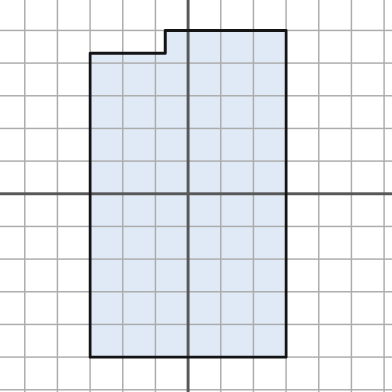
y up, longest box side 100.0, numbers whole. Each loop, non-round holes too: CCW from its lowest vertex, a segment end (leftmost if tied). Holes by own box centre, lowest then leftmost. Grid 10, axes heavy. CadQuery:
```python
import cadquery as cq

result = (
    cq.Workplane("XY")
    .moveTo(-30.0, -50.0)
    .lineTo(30.0, -50.0)
    .lineTo(30.0, 50.0)
    .lineTo(-7.0, 50.0)
    .lineTo(-7.0, 43.0)
    .lineTo(-30.0, 43.0)
    .close()
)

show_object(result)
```